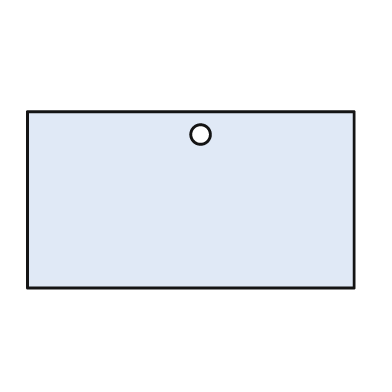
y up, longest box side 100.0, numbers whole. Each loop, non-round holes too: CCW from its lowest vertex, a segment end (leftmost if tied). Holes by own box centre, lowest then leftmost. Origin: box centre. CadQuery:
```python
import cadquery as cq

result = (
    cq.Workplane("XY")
    .moveTo(-50.0, -27.0)
    .lineTo(50.0, -27.0)
    .lineTo(50.0, 27.0)
    .lineTo(-50.0, 27.0)
    .close()
    .moveTo(3.0, 20.0)
    .circle(3.0)
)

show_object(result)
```